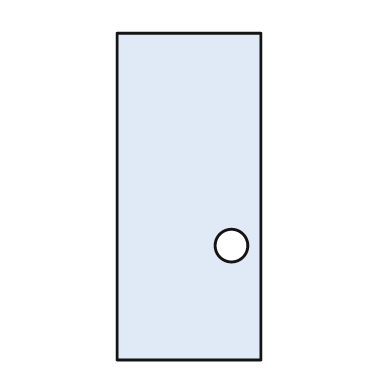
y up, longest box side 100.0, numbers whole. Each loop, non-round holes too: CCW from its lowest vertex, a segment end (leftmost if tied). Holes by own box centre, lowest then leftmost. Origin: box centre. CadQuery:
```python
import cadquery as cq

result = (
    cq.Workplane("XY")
    .moveTo(-22.0, -50.0)
    .lineTo(22.0, -50.0)
    .lineTo(22.0, 50.0)
    .lineTo(-22.0, 50.0)
    .close()
    .moveTo(13.0, -15.0)
    .circle(5.0)
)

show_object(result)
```